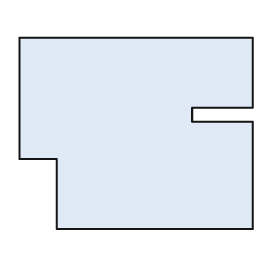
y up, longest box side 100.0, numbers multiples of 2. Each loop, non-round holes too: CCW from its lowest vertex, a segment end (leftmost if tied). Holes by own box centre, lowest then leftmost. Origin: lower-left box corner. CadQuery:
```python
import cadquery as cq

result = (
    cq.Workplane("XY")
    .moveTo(16.0, 0.0)
    .lineTo(100.0, 0.0)
    .lineTo(100.0, 46.0)
    .lineTo(74.0, 46.0)
    .lineTo(74.0, 52.0)
    .lineTo(100.0, 52.0)
    .lineTo(100.0, 82.0)
    .lineTo(0.0, 82.0)
    .lineTo(0.0, 30.0)
    .lineTo(16.0, 30.0)
    .close()
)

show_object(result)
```